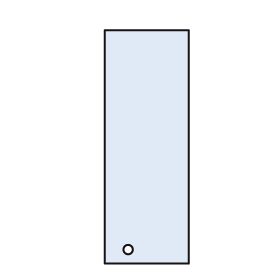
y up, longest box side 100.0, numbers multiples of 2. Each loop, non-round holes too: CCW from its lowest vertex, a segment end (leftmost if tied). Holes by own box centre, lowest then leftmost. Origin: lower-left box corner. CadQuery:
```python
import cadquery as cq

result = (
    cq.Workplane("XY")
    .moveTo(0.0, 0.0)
    .lineTo(36.0, 0.0)
    .lineTo(36.0, 100.0)
    .lineTo(0.0, 100.0)
    .close()
    .moveTo(10.0, 6.0)
    .circle(2.0)
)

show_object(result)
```